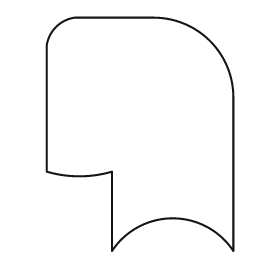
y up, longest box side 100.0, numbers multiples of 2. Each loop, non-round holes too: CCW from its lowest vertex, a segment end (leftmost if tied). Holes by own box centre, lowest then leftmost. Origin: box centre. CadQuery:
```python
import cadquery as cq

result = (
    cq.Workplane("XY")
    .moveTo(-12.0, -50.0)
    .threePointArc((14.0, -36.0), (40.0, -50.0))
    .lineTo(40.0, 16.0)
    .threePointArc((30.0, 40.0), (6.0, 50.0))
    .lineTo(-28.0, 50.0)
    .threePointArc((-36.0, 46.0), (-40.0, 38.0))
    .lineTo(-40.0, -16.0)
    .threePointArc((-26.0, -18.0), (-12.0, -16.0))
    .close()
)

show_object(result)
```